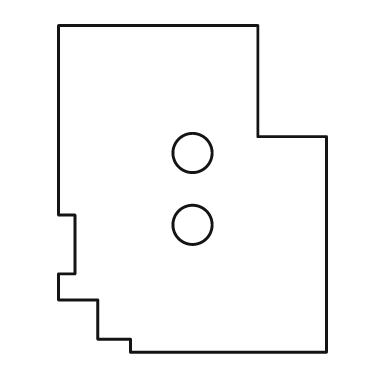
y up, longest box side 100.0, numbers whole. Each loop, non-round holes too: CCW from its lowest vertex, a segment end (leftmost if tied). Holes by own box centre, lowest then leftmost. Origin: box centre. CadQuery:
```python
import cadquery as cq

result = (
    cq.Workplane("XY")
    .moveTo(-19.0, -50.0)
    .lineTo(41.0, -50.0)
    .lineTo(41.0, 16.0)
    .lineTo(20.0, 16.0)
    .lineTo(20.0, 50.0)
    .lineTo(-41.0, 50.0)
    .lineTo(-41.0, -8.0)
    .lineTo(-36.0, -8.0)
    .lineTo(-36.0, -26.0)
    .lineTo(-41.0, -26.0)
    .lineTo(-41.0, -34.0)
    .lineTo(-29.0, -34.0)
    .lineTo(-29.0, -46.0)
    .lineTo(-19.0, -46.0)
    .close()
    .moveTo(0.0, -11.0)
    .circle(6.0)
    .moveTo(0.0, 11.0)
    .circle(6.0)
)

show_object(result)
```